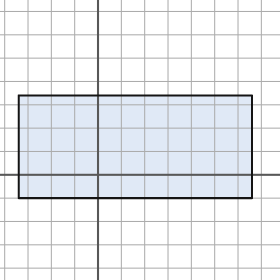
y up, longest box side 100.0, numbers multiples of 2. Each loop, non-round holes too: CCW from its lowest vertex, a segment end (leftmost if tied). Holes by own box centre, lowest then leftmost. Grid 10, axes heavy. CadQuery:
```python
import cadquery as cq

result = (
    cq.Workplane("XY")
    .moveTo(-34.0, -10.0)
    .lineTo(66.0, -10.0)
    .lineTo(66.0, 34.0)
    .lineTo(-34.0, 34.0)
    .close()
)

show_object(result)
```